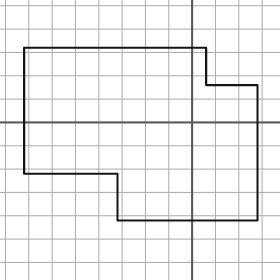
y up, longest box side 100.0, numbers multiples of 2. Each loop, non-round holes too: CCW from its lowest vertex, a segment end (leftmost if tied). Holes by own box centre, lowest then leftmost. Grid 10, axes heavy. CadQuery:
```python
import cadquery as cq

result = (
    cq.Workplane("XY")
    .moveTo(-32.0, -42.0)
    .lineTo(28.0, -42.0)
    .lineTo(28.0, 16.0)
    .lineTo(6.0, 16.0)
    .lineTo(6.0, 32.0)
    .lineTo(-72.0, 32.0)
    .lineTo(-72.0, -22.0)
    .lineTo(-32.0, -22.0)
    .close()
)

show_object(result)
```